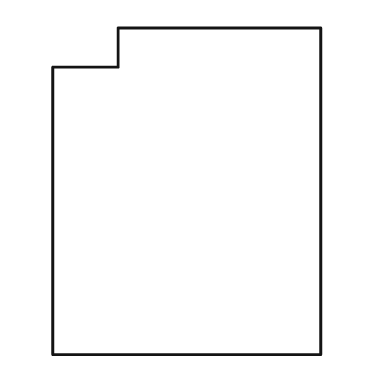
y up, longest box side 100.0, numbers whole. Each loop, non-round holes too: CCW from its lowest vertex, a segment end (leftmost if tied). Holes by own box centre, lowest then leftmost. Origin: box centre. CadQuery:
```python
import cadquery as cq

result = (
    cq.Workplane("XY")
    .moveTo(-41.0, -50.0)
    .lineTo(41.0, -50.0)
    .lineTo(41.0, 50.0)
    .lineTo(-21.0, 50.0)
    .lineTo(-21.0, 38.0)
    .lineTo(-41.0, 38.0)
    .close()
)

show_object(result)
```